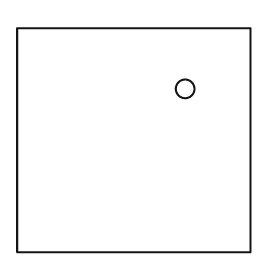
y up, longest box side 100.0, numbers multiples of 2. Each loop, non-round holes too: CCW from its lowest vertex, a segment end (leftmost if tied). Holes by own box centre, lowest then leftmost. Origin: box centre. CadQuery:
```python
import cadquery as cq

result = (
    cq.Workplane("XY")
    .moveTo(-50.0, -48.0)
    .lineTo(50.0, -48.0)
    .lineTo(50.0, 48.0)
    .lineTo(-50.0, 48.0)
    .close()
    .moveTo(22.0, 22.0)
    .circle(4.0)
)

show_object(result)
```